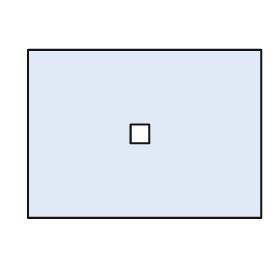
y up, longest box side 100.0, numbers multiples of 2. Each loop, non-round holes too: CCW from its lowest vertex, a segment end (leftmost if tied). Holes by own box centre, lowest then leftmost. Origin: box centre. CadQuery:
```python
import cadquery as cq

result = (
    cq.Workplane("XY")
    .moveTo(-50.0, -36.0)
    .lineTo(50.0, -36.0)
    .lineTo(50.0, 36.0)
    .lineTo(-50.0, 36.0)
    .close()
    .moveTo(-6.0, -4.0)
    .lineTo(2.0, -4.0)
    .lineTo(2.0, 4.0)
    .lineTo(-6.0, 4.0)
    .close()
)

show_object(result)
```